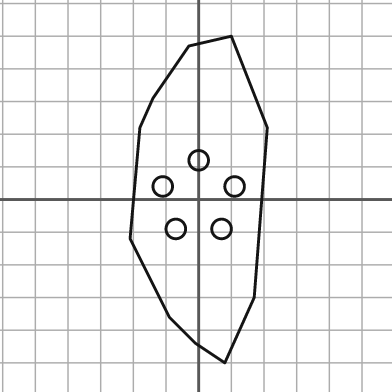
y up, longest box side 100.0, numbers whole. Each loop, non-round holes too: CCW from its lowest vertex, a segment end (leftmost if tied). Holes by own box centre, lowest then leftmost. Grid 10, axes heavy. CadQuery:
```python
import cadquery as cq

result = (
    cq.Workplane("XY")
    .moveTo(8.0, -50.0)
    .lineTo(17.0, -30.0)
    .lineTo(21.0, 22.0)
    .lineTo(10.0, 50.0)
    .lineTo(-3.0, 47.0)
    .lineTo(-14.0, 31.0)
    .lineTo(-18.0, 22.0)
    .lineTo(-21.0, -12.0)
    .lineTo(-9.0, -36.0)
    .lineTo(-1.0, -44.0)
    .close()
    .moveTo(-7.0, -9.0)
    .circle(3.0)
    .moveTo(7.0, -9.0)
    .circle(3.0)
    .moveTo(-11.0, 4.0)
    .circle(3.0)
    .moveTo(11.0, 4.0)
    .circle(3.0)
    .moveTo(0.0, 12.0)
    .circle(3.0)
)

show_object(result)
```